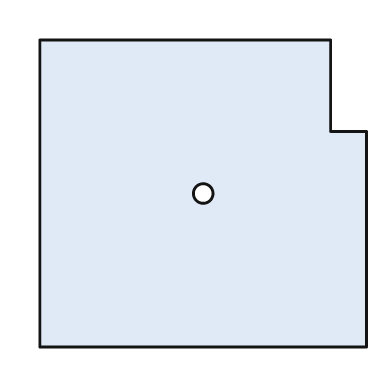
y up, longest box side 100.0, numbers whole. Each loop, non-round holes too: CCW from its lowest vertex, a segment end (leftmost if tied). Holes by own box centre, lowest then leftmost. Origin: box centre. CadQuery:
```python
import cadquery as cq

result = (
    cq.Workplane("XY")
    .moveTo(-50.0, -47.0)
    .lineTo(50.0, -47.0)
    .lineTo(50.0, 19.0)
    .lineTo(39.0, 19.0)
    .lineTo(39.0, 47.0)
    .lineTo(-50.0, 47.0)
    .close()
    .moveTo(0.0, 0.0)
    .circle(3.0)
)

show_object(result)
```